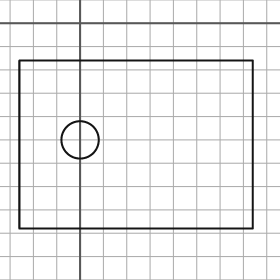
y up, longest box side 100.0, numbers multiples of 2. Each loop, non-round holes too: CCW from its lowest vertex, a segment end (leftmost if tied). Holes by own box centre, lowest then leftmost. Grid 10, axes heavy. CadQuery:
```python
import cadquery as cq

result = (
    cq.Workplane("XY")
    .moveTo(-26.0, -88.0)
    .lineTo(74.0, -88.0)
    .lineTo(74.0, -16.0)
    .lineTo(-26.0, -16.0)
    .close()
    .moveTo(0.0, -50.0)
    .circle(8.0)
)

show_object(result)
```